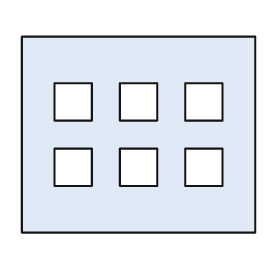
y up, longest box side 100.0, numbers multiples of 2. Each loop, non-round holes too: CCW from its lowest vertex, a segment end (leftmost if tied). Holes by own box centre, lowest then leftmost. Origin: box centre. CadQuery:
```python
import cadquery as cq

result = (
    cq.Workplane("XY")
    .moveTo(-50.0, -42.0)
    .lineTo(50.0, -42.0)
    .lineTo(50.0, 42.0)
    .lineTo(-50.0, 42.0)
    .close()
    .moveTo(-36.0, -22.0)
    .lineTo(-20.0, -22.0)
    .lineTo(-20.0, -6.0)
    .lineTo(-36.0, -6.0)
    .close()
    .moveTo(-8.0, -22.0)
    .lineTo(8.0, -22.0)
    .lineTo(8.0, -6.0)
    .lineTo(-8.0, -6.0)
    .close()
    .moveTo(20.0, -22.0)
    .lineTo(36.0, -22.0)
    .lineTo(36.0, -6.0)
    .lineTo(20.0, -6.0)
    .close()
    .moveTo(-36.0, 6.0)
    .lineTo(-20.0, 6.0)
    .lineTo(-20.0, 22.0)
    .lineTo(-36.0, 22.0)
    .close()
    .moveTo(-8.0, 6.0)
    .lineTo(8.0, 6.0)
    .lineTo(8.0, 22.0)
    .lineTo(-8.0, 22.0)
    .close()
    .moveTo(20.0, 6.0)
    .lineTo(36.0, 6.0)
    .lineTo(36.0, 22.0)
    .lineTo(20.0, 22.0)
    .close()
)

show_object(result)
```